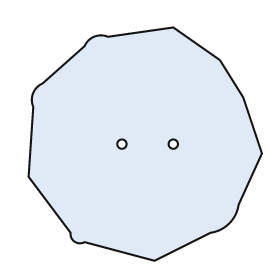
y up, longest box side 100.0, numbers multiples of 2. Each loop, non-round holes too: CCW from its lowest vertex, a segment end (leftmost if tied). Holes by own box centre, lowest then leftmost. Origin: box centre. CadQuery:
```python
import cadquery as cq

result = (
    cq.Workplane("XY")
    .moveTo(4.0, -50.0)
    .lineTo(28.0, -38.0)
    .threePointArc((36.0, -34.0), (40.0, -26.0))
    .lineTo(50.0, -4.0)
    .lineTo(42.0, 20.0)
    .lineTo(32.0, 36.0)
    .lineTo(12.0, 50.0)
    .lineTo(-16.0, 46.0)
    .threePointArc((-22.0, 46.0), (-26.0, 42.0))
    .lineTo(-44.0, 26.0)
    .threePointArc((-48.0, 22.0), (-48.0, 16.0))
    .lineTo(-50.0, -14.0)
    .lineTo(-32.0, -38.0)
    .threePointArc((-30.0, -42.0), (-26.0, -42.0))
    .close()
    .moveTo(-10.0, 0.0)
    .circle(2.0)
    .moveTo(12.0, 0.0)
    .circle(2.0)
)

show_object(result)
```